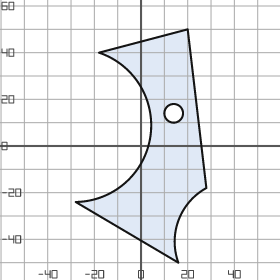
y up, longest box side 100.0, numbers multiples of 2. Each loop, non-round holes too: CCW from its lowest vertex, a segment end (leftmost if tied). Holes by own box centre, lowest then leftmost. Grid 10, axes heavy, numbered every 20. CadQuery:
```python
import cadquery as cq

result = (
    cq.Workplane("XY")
    .moveTo(16.0, -50.0)
    .threePointArc((16.0, -32.0), (28.0, -18.0))
    .lineTo(20.0, 50.0)
    .lineTo(-18.0, 40.0)
    .threePointArc((4.0, 4.0), (-28.0, -24.0))
    .close()
    .moveTo(14.0, 14.0)
    .circle(4.0)
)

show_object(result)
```